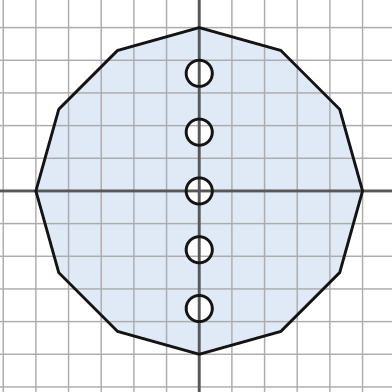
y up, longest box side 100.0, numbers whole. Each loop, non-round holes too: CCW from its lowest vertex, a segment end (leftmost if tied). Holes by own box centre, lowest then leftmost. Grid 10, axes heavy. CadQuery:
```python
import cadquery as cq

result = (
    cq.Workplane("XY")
    .moveTo(0.0, -50.0)
    .lineTo(25.0, -43.0)
    .lineTo(43.0, -25.0)
    .lineTo(50.0, 0.0)
    .lineTo(43.0, 25.0)
    .lineTo(25.0, 43.0)
    .lineTo(0.0, 50.0)
    .lineTo(-25.0, 43.0)
    .lineTo(-43.0, 25.0)
    .lineTo(-50.0, 0.0)
    .lineTo(-43.0, -25.0)
    .lineTo(-25.0, -43.0)
    .close()
    .moveTo(0.0, -36.0)
    .circle(4.0)
    .moveTo(0.0, -18.0)
    .circle(4.0)
    .moveTo(0.0, 0.0)
    .circle(4.0)
    .moveTo(0.0, 18.0)
    .circle(4.0)
    .moveTo(0.0, 36.0)
    .circle(4.0)
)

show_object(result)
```